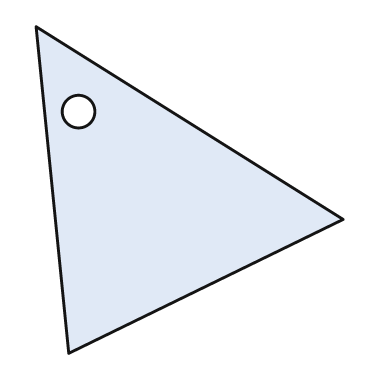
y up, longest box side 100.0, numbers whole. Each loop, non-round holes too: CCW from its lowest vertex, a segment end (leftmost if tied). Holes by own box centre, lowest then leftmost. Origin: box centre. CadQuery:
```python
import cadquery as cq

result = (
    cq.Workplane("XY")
    .moveTo(-37.0, -50.0)
    .lineTo(47.0, -9.0)
    .lineTo(-47.0, 50.0)
    .close()
    .moveTo(-34.0, 24.0)
    .circle(5.0)
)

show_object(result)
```